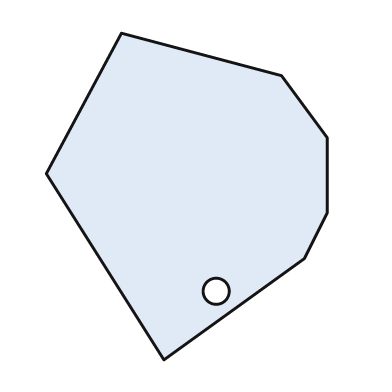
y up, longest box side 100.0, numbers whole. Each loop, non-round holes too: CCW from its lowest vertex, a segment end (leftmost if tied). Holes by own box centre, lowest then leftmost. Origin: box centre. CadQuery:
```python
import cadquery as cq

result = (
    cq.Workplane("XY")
    .moveTo(-7.0, -50.0)
    .lineTo(36.0, -19.0)
    .lineTo(43.0, -5.0)
    .lineTo(43.0, 18.0)
    .lineTo(29.0, 37.0)
    .lineTo(-20.0, 50.0)
    .lineTo(-43.0, 7.0)
    .close()
    .moveTo(9.0, -29.0)
    .circle(4.0)
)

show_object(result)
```